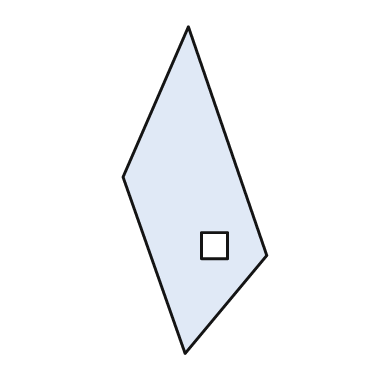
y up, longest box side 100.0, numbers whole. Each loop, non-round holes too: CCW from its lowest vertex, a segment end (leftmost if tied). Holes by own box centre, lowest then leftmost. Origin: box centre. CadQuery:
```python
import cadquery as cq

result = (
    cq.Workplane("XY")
    .moveTo(-3.0, -50.0)
    .lineTo(22.0, -20.0)
    .lineTo(-2.0, 50.0)
    .lineTo(-22.0, 4.0)
    .close()
    .moveTo(2.0, -21.0)
    .lineTo(10.0, -21.0)
    .lineTo(10.0, -13.0)
    .lineTo(2.0, -13.0)
    .close()
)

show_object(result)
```